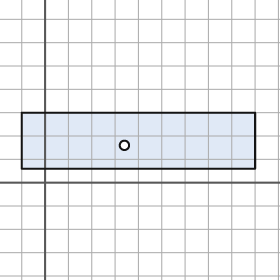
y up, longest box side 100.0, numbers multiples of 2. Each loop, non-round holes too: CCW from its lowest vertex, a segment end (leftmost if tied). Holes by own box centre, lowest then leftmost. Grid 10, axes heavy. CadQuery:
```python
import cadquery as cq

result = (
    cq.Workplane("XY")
    .moveTo(-10.0, 6.0)
    .lineTo(90.0, 6.0)
    .lineTo(90.0, 30.0)
    .lineTo(-10.0, 30.0)
    .close()
    .moveTo(34.0, 16.0)
    .circle(2.0)
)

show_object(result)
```